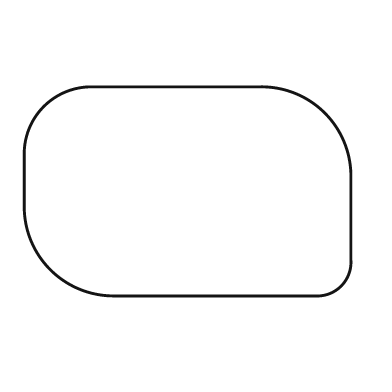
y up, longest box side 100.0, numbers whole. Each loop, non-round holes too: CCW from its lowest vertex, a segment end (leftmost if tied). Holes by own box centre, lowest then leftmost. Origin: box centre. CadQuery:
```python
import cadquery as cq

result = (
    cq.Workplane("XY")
    .moveTo(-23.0, -32.0)
    .lineTo(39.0, -32.0)
    .threePointArc((47.0, -29.0), (50.0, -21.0))
    .lineTo(50.0, 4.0)
    .threePointArc((42.0, 24.0), (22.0, 32.0))
    .lineTo(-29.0, 32.0)
    .threePointArc((-44.0, 26.0), (-50.0, 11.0))
    .lineTo(-50.0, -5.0)
    .threePointArc((-42.0, -24.0), (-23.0, -32.0))
    .close()
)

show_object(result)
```